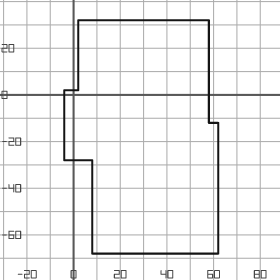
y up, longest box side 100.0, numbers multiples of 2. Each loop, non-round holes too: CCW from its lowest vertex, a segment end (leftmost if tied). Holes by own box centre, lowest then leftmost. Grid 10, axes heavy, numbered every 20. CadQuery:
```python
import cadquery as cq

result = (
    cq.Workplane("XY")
    .moveTo(8.0, -68.0)
    .lineTo(62.0, -68.0)
    .lineTo(62.0, -12.0)
    .lineTo(58.0, -12.0)
    .lineTo(58.0, 32.0)
    .lineTo(2.0, 32.0)
    .lineTo(2.0, 2.0)
    .lineTo(-4.0, 2.0)
    .lineTo(-4.0, -28.0)
    .lineTo(8.0, -28.0)
    .close()
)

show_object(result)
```